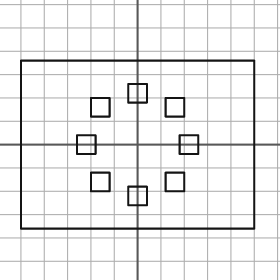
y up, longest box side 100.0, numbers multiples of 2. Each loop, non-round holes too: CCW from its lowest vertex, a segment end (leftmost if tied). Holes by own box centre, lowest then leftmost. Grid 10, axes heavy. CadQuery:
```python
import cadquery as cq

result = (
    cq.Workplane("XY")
    .moveTo(-50.0, -36.0)
    .lineTo(50.0, -36.0)
    .lineTo(50.0, 36.0)
    .lineTo(-50.0, 36.0)
    .close()
    .moveTo(-4.0, -26.0)
    .lineTo(4.0, -26.0)
    .lineTo(4.0, -18.0)
    .lineTo(-4.0, -18.0)
    .close()
    .moveTo(-20.0, -20.0)
    .lineTo(-12.0, -20.0)
    .lineTo(-12.0, -12.0)
    .lineTo(-20.0, -12.0)
    .close()
    .moveTo(12.0, -20.0)
    .lineTo(20.0, -20.0)
    .lineTo(20.0, -12.0)
    .lineTo(12.0, -12.0)
    .close()
    .moveTo(-26.0, -4.0)
    .lineTo(-18.0, -4.0)
    .lineTo(-18.0, 4.0)
    .lineTo(-26.0, 4.0)
    .close()
    .moveTo(18.0, -4.0)
    .lineTo(26.0, -4.0)
    .lineTo(26.0, 4.0)
    .lineTo(18.0, 4.0)
    .close()
    .moveTo(-20.0, 12.0)
    .lineTo(-12.0, 12.0)
    .lineTo(-12.0, 20.0)
    .lineTo(-20.0, 20.0)
    .close()
    .moveTo(12.0, 12.0)
    .lineTo(20.0, 12.0)
    .lineTo(20.0, 20.0)
    .lineTo(12.0, 20.0)
    .close()
    .moveTo(-4.0, 18.0)
    .lineTo(4.0, 18.0)
    .lineTo(4.0, 26.0)
    .lineTo(-4.0, 26.0)
    .close()
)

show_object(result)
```